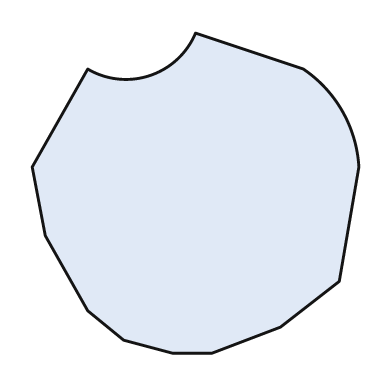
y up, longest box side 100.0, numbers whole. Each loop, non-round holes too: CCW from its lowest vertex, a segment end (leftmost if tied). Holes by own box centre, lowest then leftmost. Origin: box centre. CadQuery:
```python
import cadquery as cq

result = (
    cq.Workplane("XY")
    .moveTo(-7.0, -49.0)
    .lineTo(5.0, -49.0)
    .lineTo(26.0, -41.0)
    .lineTo(44.0, -27.0)
    .lineTo(50.0, 8.0)
    .threePointArc((45.0, 25.0), (33.0, 38.0))
    .lineTo(0.0, 49.0)
    .threePointArc((-14.0, 36.0), (-33.0, 38.0))
    .lineTo(-50.0, 8.0)
    .lineTo(-46.0, -13.0)
    .lineTo(-33.0, -36.0)
    .lineTo(-22.0, -45.0)
    .close()
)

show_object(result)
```